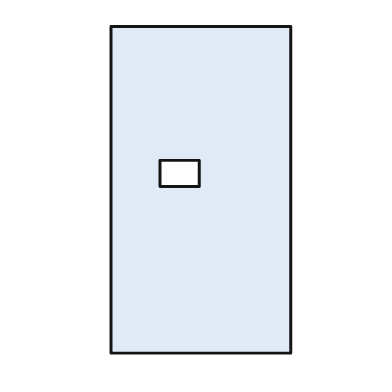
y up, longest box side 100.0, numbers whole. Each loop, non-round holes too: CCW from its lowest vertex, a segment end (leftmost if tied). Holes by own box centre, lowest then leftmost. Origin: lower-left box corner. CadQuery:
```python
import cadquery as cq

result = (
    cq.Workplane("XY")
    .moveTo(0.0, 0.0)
    .lineTo(55.0, 0.0)
    .lineTo(55.0, 100.0)
    .lineTo(0.0, 100.0)
    .close()
    .moveTo(15.0, 51.0)
    .lineTo(27.0, 51.0)
    .lineTo(27.0, 59.0)
    .lineTo(15.0, 59.0)
    .close()
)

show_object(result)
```